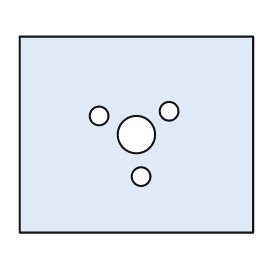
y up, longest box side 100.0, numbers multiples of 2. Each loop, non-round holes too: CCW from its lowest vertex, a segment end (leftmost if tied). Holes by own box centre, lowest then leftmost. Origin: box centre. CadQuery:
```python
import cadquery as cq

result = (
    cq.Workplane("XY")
    .moveTo(-50.0, -42.0)
    .lineTo(50.0, -42.0)
    .lineTo(50.0, 42.0)
    .lineTo(-50.0, 42.0)
    .close()
    .moveTo(2.0, -18.0)
    .circle(4.0)
    .moveTo(0.0, 0.0)
    .circle(8.0)
    .moveTo(-16.0, 8.0)
    .circle(4.0)
    .moveTo(14.0, 10.0)
    .circle(4.0)
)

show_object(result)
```